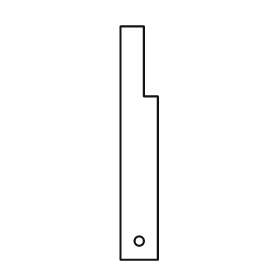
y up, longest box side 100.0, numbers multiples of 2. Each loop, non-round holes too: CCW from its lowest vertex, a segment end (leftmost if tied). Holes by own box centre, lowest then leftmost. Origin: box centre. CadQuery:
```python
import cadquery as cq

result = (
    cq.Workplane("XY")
    .moveTo(-8.0, -50.0)
    .lineTo(8.0, -50.0)
    .lineTo(8.0, 20.0)
    .lineTo(2.0, 20.0)
    .lineTo(2.0, 50.0)
    .lineTo(-8.0, 50.0)
    .close()
    .moveTo(0.0, -42.0)
    .circle(2.0)
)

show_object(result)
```